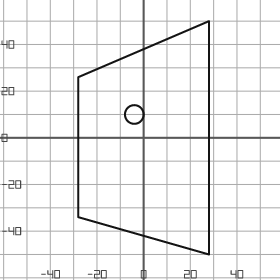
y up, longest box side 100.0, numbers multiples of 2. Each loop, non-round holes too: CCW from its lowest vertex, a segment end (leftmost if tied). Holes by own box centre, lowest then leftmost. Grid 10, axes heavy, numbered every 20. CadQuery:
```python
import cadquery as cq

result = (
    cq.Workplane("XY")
    .moveTo(28.0, -50.0)
    .lineTo(28.0, 50.0)
    .lineTo(-28.0, 26.0)
    .lineTo(-28.0, -34.0)
    .close()
    .moveTo(-4.0, 10.0)
    .circle(4.0)
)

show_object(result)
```